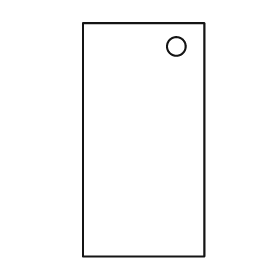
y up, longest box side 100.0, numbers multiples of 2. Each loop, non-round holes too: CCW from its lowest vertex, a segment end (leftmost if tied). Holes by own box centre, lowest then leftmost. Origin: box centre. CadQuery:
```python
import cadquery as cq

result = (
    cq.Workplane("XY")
    .moveTo(-26.0, -50.0)
    .lineTo(26.0, -50.0)
    .lineTo(26.0, 50.0)
    .lineTo(-26.0, 50.0)
    .close()
    .moveTo(14.0, 40.0)
    .circle(4.0)
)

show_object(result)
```